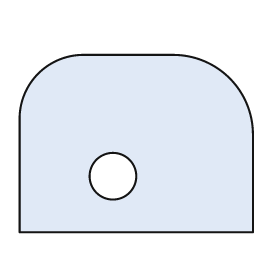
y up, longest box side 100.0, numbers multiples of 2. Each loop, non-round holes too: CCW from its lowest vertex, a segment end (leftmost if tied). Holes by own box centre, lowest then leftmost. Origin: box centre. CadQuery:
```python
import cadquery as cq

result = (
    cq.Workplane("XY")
    .moveTo(-50.0, -38.0)
    .lineTo(50.0, -38.0)
    .lineTo(50.0, 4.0)
    .threePointArc((40.0, 28.0), (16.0, 38.0))
    .lineTo(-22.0, 38.0)
    .threePointArc((-42.0, 30.0), (-50.0, 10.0))
    .close()
    .moveTo(-10.0, -14.0)
    .circle(10.0)
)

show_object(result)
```